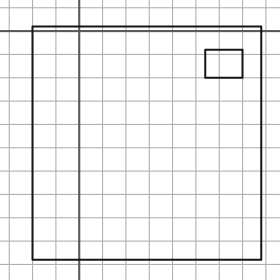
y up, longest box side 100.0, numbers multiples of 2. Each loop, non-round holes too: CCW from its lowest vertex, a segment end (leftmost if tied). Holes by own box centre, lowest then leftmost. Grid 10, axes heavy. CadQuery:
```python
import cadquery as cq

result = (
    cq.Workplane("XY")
    .moveTo(-20.0, -98.0)
    .lineTo(78.0, -98.0)
    .lineTo(78.0, 2.0)
    .lineTo(-20.0, 2.0)
    .close()
    .moveTo(54.0, -20.0)
    .lineTo(70.0, -20.0)
    .lineTo(70.0, -8.0)
    .lineTo(54.0, -8.0)
    .close()
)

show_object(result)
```